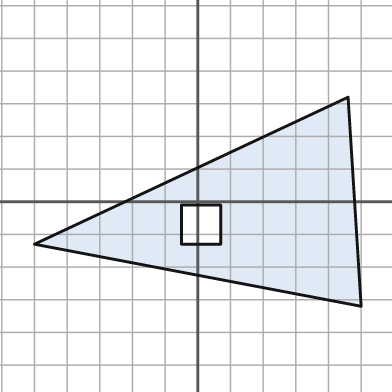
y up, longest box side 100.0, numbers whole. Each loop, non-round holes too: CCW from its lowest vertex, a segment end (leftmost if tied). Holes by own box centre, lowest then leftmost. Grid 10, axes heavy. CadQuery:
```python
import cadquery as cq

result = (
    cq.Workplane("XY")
    .moveTo(50.0, -32.0)
    .lineTo(46.0, 32.0)
    .lineTo(-50.0, -13.0)
    .close()
    .moveTo(-5.0, -13.0)
    .lineTo(7.0, -13.0)
    .lineTo(7.0, -1.0)
    .lineTo(-5.0, -1.0)
    .close()
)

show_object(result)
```